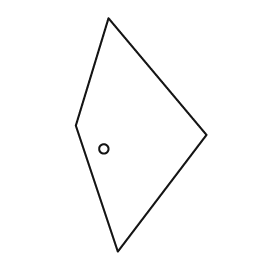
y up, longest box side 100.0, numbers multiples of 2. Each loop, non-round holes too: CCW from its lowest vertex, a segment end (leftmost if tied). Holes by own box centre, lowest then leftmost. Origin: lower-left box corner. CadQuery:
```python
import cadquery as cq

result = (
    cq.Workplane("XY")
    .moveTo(18.0, 0.0)
    .lineTo(56.0, 50.0)
    .lineTo(14.0, 100.0)
    .lineTo(0.0, 54.0)
    .close()
    .moveTo(12.0, 44.0)
    .circle(2.0)
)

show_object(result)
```